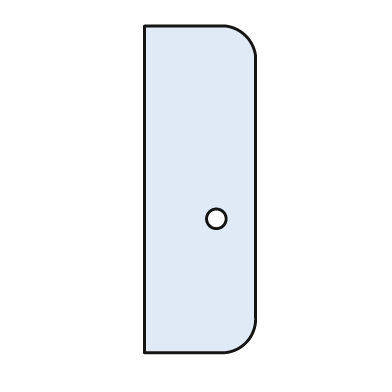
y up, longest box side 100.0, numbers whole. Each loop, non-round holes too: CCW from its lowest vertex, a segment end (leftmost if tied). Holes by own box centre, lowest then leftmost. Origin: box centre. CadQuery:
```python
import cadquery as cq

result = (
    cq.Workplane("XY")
    .moveTo(-17.0, -50.0)
    .lineTo(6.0, -50.0)
    .threePointArc((14.0, -47.0), (17.0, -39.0))
    .lineTo(17.0, 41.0)
    .threePointArc((14.0, 47.0), (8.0, 50.0))
    .lineTo(-17.0, 50.0)
    .close()
    .moveTo(5.0, -9.0)
    .circle(3.0)
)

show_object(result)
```